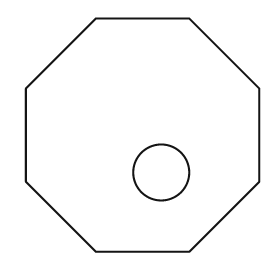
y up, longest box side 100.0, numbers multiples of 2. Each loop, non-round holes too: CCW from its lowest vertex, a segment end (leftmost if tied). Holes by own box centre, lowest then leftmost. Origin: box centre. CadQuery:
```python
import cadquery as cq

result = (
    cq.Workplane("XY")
    .moveTo(-20.0, -50.0)
    .lineTo(20.0, -50.0)
    .lineTo(50.0, -20.0)
    .lineTo(50.0, 20.0)
    .lineTo(20.0, 50.0)
    .lineTo(-20.0, 50.0)
    .lineTo(-50.0, 20.0)
    .lineTo(-50.0, -20.0)
    .close()
    .moveTo(8.0, -16.0)
    .circle(12.0)
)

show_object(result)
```